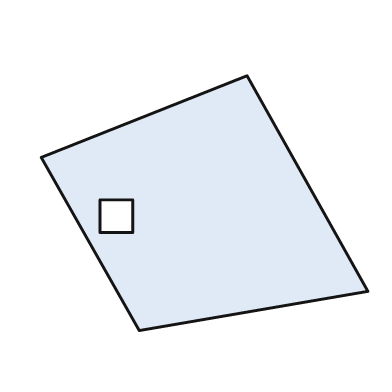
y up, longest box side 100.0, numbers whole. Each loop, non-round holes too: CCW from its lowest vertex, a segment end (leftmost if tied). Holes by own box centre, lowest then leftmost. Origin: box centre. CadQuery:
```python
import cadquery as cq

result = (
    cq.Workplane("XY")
    .moveTo(-20.0, -39.0)
    .lineTo(50.0, -27.0)
    .lineTo(13.0, 39.0)
    .lineTo(-50.0, 14.0)
    .close()
    .moveTo(-32.0, -9.0)
    .lineTo(-22.0, -9.0)
    .lineTo(-22.0, 1.0)
    .lineTo(-32.0, 1.0)
    .close()
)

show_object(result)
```